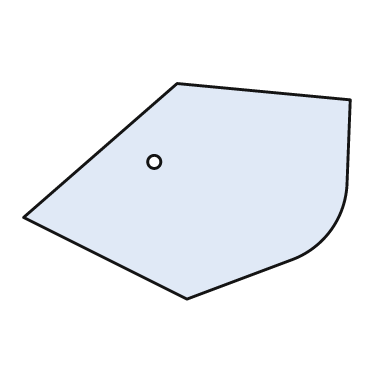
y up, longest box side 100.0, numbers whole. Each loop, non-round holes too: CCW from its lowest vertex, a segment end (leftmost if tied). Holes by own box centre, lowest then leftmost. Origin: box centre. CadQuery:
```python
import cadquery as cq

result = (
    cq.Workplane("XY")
    .moveTo(0.0, -33.0)
    .lineTo(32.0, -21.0)
    .threePointArc((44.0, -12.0), (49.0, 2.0))
    .lineTo(50.0, 28.0)
    .lineTo(-3.0, 33.0)
    .lineTo(-50.0, -8.0)
    .close()
    .moveTo(-10.0, 9.0)
    .circle(2.0)
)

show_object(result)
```